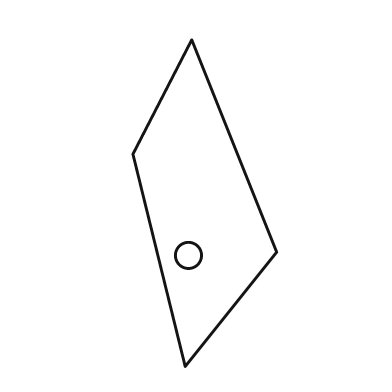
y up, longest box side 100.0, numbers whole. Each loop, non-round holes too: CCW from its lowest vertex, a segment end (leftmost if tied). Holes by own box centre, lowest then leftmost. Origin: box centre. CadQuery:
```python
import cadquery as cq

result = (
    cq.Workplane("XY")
    .moveTo(-6.0, -50.0)
    .lineTo(22.0, -15.0)
    .lineTo(-4.0, 50.0)
    .lineTo(-22.0, 15.0)
    .close()
    .moveTo(-5.0, -16.0)
    .circle(4.0)
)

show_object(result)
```